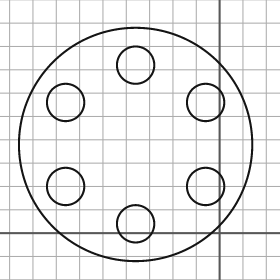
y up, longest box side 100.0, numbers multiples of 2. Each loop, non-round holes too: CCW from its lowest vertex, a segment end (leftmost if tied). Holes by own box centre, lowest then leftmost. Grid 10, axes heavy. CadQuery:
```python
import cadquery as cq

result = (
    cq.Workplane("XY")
    .moveTo(-36.0, 38.0)
    .circle(50.0)
    .moveTo(-36.0, 4.0)
    .circle(8.0)
    .moveTo(-66.0, 20.0)
    .circle(8.0)
    .moveTo(-6.0, 20.0)
    .circle(8.0)
    .moveTo(-66.0, 56.0)
    .circle(8.0)
    .moveTo(-6.0, 56.0)
    .circle(8.0)
    .moveTo(-36.0, 72.0)
    .circle(8.0)
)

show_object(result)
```